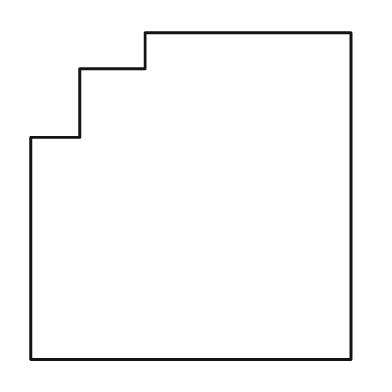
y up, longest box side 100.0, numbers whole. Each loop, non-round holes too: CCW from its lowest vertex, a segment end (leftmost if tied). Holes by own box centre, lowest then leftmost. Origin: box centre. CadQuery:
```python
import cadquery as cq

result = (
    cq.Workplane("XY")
    .moveTo(-49.0, -50.0)
    .lineTo(49.0, -50.0)
    .lineTo(49.0, 50.0)
    .lineTo(-14.0, 50.0)
    .lineTo(-14.0, 39.0)
    .lineTo(-34.0, 39.0)
    .lineTo(-34.0, 18.0)
    .lineTo(-49.0, 18.0)
    .close()
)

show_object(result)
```